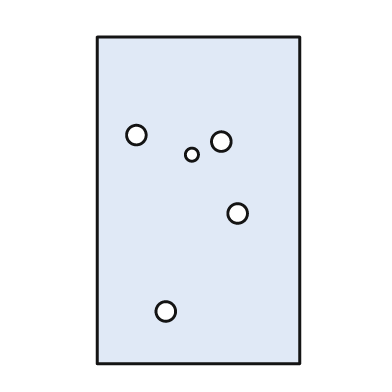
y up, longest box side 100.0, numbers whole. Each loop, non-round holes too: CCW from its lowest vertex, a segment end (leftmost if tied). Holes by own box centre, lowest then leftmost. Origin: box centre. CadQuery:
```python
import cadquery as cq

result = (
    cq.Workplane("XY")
    .moveTo(-31.0, -50.0)
    .lineTo(31.0, -50.0)
    .lineTo(31.0, 50.0)
    .lineTo(-31.0, 50.0)
    .close()
    .moveTo(-10.0, -34.0)
    .circle(3.0)
    .moveTo(12.0, -4.0)
    .circle(3.0)
    .moveTo(-2.0, 14.0)
    .circle(2.0)
    .moveTo(7.0, 18.0)
    .circle(3.0)
    .moveTo(-19.0, 20.0)
    .circle(3.0)
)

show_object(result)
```